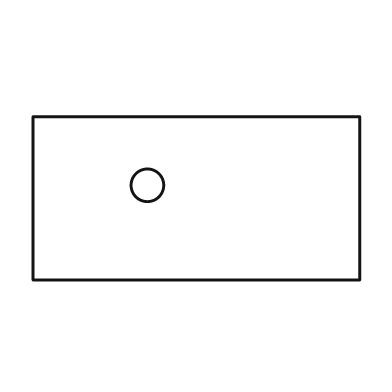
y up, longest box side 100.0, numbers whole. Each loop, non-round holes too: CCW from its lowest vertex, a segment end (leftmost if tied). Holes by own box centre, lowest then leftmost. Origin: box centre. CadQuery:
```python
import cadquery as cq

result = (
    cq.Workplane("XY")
    .moveTo(-50.0, -25.0)
    .lineTo(50.0, -25.0)
    .lineTo(50.0, 25.0)
    .lineTo(-50.0, 25.0)
    .close()
    .moveTo(-15.0, 4.0)
    .circle(5.0)
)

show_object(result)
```